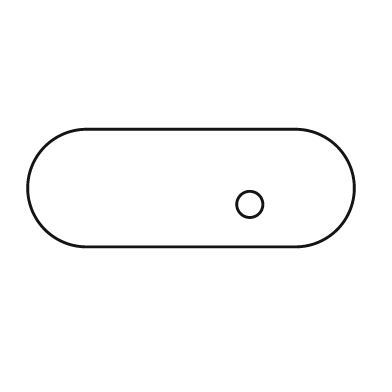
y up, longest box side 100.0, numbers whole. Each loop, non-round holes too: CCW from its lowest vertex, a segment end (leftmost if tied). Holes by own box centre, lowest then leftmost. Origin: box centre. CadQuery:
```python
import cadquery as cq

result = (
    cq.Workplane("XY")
    .moveTo(-32.0, -18.0)
    .lineTo(32.0, -18.0)
    .threePointArc((50.0, 0.0), (32.0, 18.0))
    .lineTo(-32.0, 18.0)
    .threePointArc((-50.0, 0.0), (-32.0, -18.0))
    .close()
    .moveTo(18.0, -5.0)
    .circle(4.0)
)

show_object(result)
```